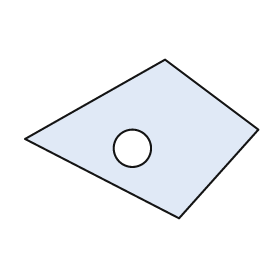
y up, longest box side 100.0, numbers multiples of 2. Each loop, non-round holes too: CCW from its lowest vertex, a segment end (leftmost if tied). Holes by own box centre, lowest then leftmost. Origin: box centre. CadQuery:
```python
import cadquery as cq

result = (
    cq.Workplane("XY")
    .moveTo(16.0, -34.0)
    .lineTo(50.0, 4.0)
    .lineTo(10.0, 34.0)
    .lineTo(-50.0, 0.0)
    .close()
    .moveTo(-4.0, -4.0)
    .circle(8.0)
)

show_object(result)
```